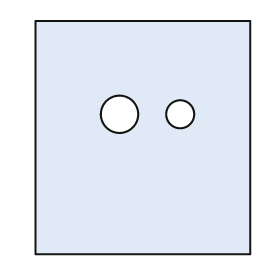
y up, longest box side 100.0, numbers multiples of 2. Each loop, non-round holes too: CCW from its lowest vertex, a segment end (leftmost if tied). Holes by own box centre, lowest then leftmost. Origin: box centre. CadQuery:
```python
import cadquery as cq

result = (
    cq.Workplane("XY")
    .moveTo(-46.0, -50.0)
    .lineTo(46.0, -50.0)
    .lineTo(46.0, 50.0)
    .lineTo(-46.0, 50.0)
    .close()
    .moveTo(-10.0, 10.0)
    .circle(8.0)
    .moveTo(16.0, 10.0)
    .circle(6.0)
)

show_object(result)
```